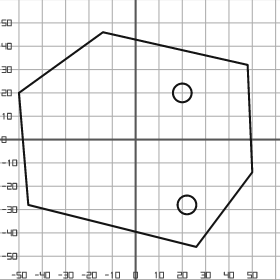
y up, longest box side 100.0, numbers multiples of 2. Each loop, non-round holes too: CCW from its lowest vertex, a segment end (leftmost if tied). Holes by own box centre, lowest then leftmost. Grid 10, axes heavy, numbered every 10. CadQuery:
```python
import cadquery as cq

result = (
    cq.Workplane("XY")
    .moveTo(26.0, -46.0)
    .lineTo(50.0, -14.0)
    .lineTo(48.0, 32.0)
    .lineTo(-14.0, 46.0)
    .lineTo(-50.0, 20.0)
    .lineTo(-46.0, -28.0)
    .close()
    .moveTo(22.0, -28.0)
    .circle(4.0)
    .moveTo(20.0, 20.0)
    .circle(4.0)
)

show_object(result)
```